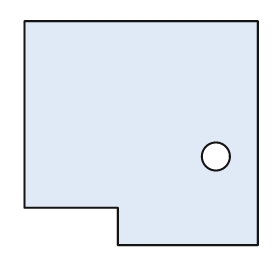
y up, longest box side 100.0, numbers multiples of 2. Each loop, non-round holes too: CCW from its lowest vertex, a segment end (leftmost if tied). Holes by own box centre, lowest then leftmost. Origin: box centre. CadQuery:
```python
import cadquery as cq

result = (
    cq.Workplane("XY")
    .moveTo(-10.0, -48.0)
    .lineTo(50.0, -48.0)
    .lineTo(50.0, 48.0)
    .lineTo(-50.0, 48.0)
    .lineTo(-50.0, -32.0)
    .lineTo(-10.0, -32.0)
    .close()
    .moveTo(32.0, -10.0)
    .circle(6.0)
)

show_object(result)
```